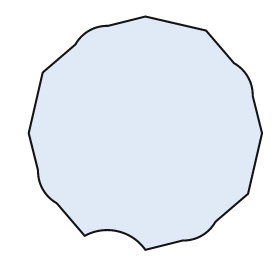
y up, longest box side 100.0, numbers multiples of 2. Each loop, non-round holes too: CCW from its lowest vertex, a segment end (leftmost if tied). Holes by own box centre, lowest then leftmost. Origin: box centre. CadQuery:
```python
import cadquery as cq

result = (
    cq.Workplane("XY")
    .moveTo(0.0, -50.0)
    .lineTo(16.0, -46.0)
    .threePointArc((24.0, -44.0), (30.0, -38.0))
    .lineTo(44.0, -26.0)
    .lineTo(50.0, 0.0)
    .lineTo(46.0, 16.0)
    .threePointArc((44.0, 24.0), (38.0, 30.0))
    .lineTo(26.0, 44.0)
    .lineTo(0.0, 50.0)
    .lineTo(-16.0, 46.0)
    .threePointArc((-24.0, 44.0), (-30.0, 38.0))
    .lineTo(-44.0, 26.0)
    .lineTo(-50.0, 0.0)
    .lineTo(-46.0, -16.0)
    .threePointArc((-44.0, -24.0), (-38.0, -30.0))
    .lineTo(-26.0, -44.0)
    .threePointArc((-12.0, -42.0), (0.0, -50.0))
    .close()
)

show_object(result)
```